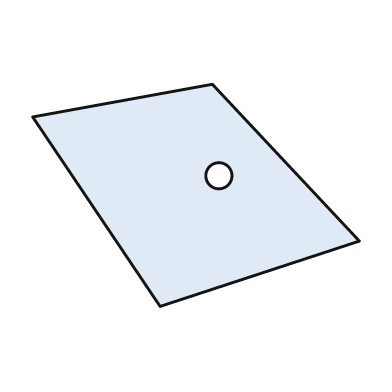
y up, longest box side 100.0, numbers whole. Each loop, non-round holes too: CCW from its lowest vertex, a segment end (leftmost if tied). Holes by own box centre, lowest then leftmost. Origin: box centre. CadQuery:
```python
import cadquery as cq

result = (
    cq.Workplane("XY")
    .moveTo(-11.0, -34.0)
    .lineTo(50.0, -14.0)
    .lineTo(5.0, 34.0)
    .lineTo(-50.0, 24.0)
    .close()
    .moveTo(7.0, 6.0)
    .circle(4.0)
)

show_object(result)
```